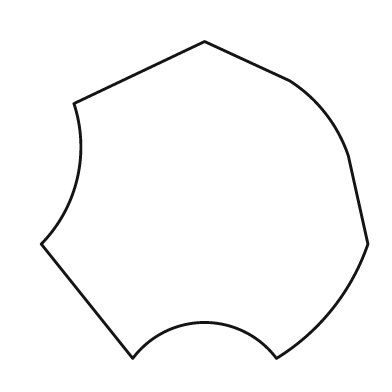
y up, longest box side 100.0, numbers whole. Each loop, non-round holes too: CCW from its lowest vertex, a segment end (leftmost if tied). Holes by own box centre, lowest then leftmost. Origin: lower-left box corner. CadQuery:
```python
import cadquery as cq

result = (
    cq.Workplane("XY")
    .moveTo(28.0, 0.0)
    .threePointArc((50.0, 11.0), (72.0, 0.0))
    .threePointArc((89.0, 15.0), (100.0, 35.0))
    .lineTo(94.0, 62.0)
    .threePointArc((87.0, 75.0), (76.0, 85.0))
    .lineTo(50.0, 97.0)
    .lineTo(10.0, 78.0)
    .threePointArc((11.0, 55.0), (0.0, 35.0))
    .close()
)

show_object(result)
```